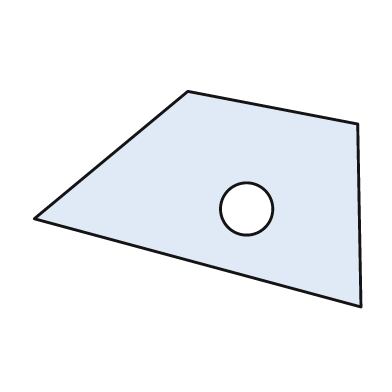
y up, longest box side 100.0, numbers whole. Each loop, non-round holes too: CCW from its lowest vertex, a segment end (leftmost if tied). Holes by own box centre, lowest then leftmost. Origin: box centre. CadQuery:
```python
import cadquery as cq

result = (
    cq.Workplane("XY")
    .moveTo(50.0, -33.0)
    .lineTo(49.0, 23.0)
    .lineTo(-3.0, 33.0)
    .lineTo(-50.0, -6.0)
    .close()
    .moveTo(15.0, -3.0)
    .circle(8.0)
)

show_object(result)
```